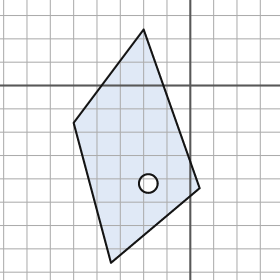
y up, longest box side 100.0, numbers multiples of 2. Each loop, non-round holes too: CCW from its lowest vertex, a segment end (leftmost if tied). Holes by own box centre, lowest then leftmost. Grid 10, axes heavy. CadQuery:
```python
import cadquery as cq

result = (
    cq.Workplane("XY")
    .moveTo(-34.0, -76.0)
    .lineTo(4.0, -44.0)
    .lineTo(-20.0, 24.0)
    .lineTo(-50.0, -16.0)
    .close()
    .moveTo(-18.0, -42.0)
    .circle(4.0)
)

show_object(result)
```